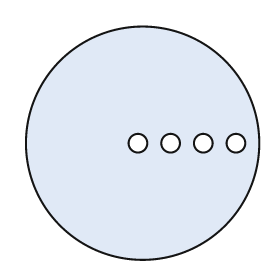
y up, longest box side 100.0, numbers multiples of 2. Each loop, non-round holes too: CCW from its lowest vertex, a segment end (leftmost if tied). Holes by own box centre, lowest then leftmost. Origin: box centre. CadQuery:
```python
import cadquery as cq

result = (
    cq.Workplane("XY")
    .moveTo(0.0, 0.0)
    .circle(50.0)
    .moveTo(-2.0, 0.0)
    .circle(4.0)
    .moveTo(12.0, 0.0)
    .circle(4.0)
    .moveTo(26.0, 0.0)
    .circle(4.0)
    .moveTo(40.0, 0.0)
    .circle(4.0)
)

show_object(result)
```